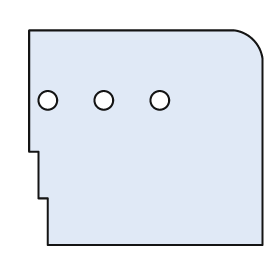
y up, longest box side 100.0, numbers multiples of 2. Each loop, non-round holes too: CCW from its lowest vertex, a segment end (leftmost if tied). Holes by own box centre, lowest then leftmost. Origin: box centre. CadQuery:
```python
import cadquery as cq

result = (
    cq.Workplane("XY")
    .moveTo(-42.0, -46.0)
    .lineTo(50.0, -46.0)
    .lineTo(50.0, 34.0)
    .threePointArc((46.0, 42.0), (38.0, 46.0))
    .lineTo(-50.0, 46.0)
    .lineTo(-50.0, -6.0)
    .lineTo(-46.0, -6.0)
    .lineTo(-46.0, -26.0)
    .lineTo(-42.0, -26.0)
    .close()
    .moveTo(-42.0, 16.0)
    .circle(4.0)
    .moveTo(-18.0, 16.0)
    .circle(4.0)
    .moveTo(6.0, 16.0)
    .circle(4.0)
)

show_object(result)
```